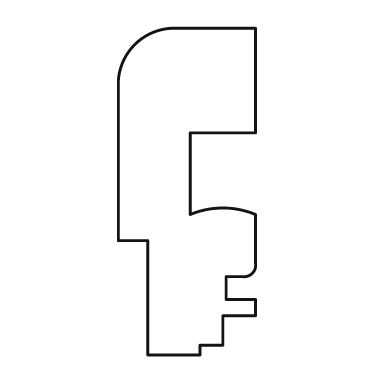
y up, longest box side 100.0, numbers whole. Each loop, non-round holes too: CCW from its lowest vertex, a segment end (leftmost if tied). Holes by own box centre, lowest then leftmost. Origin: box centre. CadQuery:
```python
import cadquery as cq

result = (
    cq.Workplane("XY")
    .moveTo(-12.0, -50.0)
    .lineTo(4.0, -50.0)
    .lineTo(4.0, -47.0)
    .lineTo(11.0, -47.0)
    .lineTo(11.0, -38.0)
    .lineTo(21.0, -38.0)
    .lineTo(21.0, -33.0)
    .lineTo(12.0, -33.0)
    .lineTo(12.0, -26.0)
    .lineTo(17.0, -26.0)
    .threePointArc((20.0, -25.0), (21.0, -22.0))
    .lineTo(21.0, -7.0)
    .threePointArc((11.0, -5.0), (1.0, -7.0))
    .lineTo(1.0, 18.0)
    .lineTo(21.0, 18.0)
    .lineTo(21.0, 50.0)
    .lineTo(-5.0, 50.0)
    .threePointArc((-16.0, 45.0), (-21.0, 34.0))
    .lineTo(-21.0, -15.0)
    .lineTo(-12.0, -15.0)
    .close()
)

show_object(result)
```